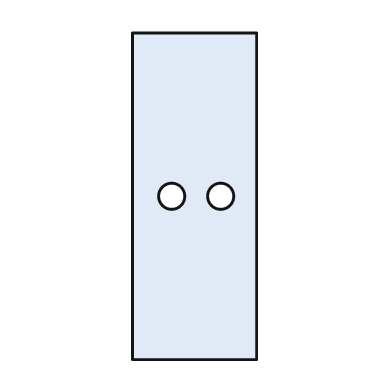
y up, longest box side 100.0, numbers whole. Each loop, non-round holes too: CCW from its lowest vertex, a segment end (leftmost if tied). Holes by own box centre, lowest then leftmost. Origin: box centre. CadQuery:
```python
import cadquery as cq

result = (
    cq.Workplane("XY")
    .moveTo(-19.0, -50.0)
    .lineTo(19.0, -50.0)
    .lineTo(19.0, 50.0)
    .lineTo(-19.0, 50.0)
    .close()
    .moveTo(-7.0, 0.0)
    .circle(4.0)
    .moveTo(8.0, 0.0)
    .circle(4.0)
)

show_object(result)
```